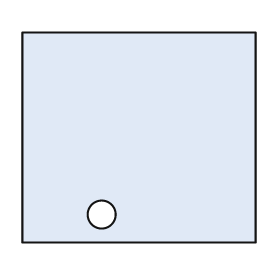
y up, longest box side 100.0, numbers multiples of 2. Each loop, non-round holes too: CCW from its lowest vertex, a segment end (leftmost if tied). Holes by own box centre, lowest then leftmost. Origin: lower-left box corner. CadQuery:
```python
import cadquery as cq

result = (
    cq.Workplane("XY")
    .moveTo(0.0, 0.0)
    .lineTo(100.0, 0.0)
    .lineTo(100.0, 90.0)
    .lineTo(0.0, 90.0)
    .close()
    .moveTo(34.0, 12.0)
    .circle(6.0)
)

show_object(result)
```